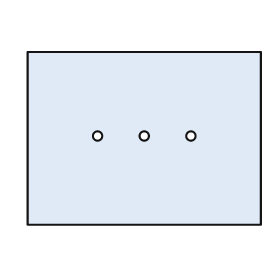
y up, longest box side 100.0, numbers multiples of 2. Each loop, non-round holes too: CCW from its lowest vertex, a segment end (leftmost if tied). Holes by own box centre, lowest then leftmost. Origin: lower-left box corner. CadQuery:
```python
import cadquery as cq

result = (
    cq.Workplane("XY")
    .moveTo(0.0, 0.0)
    .lineTo(100.0, 0.0)
    .lineTo(100.0, 74.0)
    .lineTo(0.0, 74.0)
    .close()
    .moveTo(30.0, 38.0)
    .circle(2.0)
    .moveTo(50.0, 38.0)
    .circle(2.0)
    .moveTo(70.0, 38.0)
    .circle(2.0)
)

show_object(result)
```